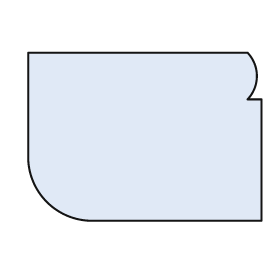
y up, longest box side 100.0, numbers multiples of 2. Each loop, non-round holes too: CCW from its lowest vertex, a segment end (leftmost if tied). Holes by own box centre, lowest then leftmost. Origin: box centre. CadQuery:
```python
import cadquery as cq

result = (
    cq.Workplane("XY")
    .moveTo(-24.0, -36.0)
    .lineTo(50.0, -36.0)
    .lineTo(50.0, 16.0)
    .lineTo(44.0, 16.0)
    .threePointArc((48.0, 26.0), (44.0, 36.0))
    .lineTo(-50.0, 36.0)
    .lineTo(-50.0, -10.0)
    .threePointArc((-42.0, -28.0), (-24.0, -36.0))
    .close()
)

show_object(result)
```